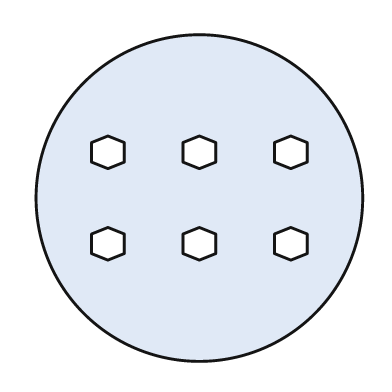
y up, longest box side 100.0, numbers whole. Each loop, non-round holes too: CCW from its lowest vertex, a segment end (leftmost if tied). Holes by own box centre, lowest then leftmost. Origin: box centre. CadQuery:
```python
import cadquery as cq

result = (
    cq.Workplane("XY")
    .moveTo(0.0, 0.0)
    .circle(50.0)
    .moveTo(-28.0, -19.0)
    .lineTo(-23.0, -17.0)
    .lineTo(-23.0, -11.0)
    .lineTo(-28.0, -9.0)
    .lineTo(-33.0, -11.0)
    .lineTo(-33.0, -17.0)
    .close()
    .moveTo(0.0, -19.0)
    .lineTo(5.0, -17.0)
    .lineTo(5.0, -11.0)
    .lineTo(0.0, -9.0)
    .lineTo(-5.0, -11.0)
    .lineTo(-5.0, -17.0)
    .close()
    .moveTo(28.0, -19.0)
    .lineTo(33.0, -17.0)
    .lineTo(33.0, -11.0)
    .lineTo(28.0, -9.0)
    .lineTo(23.0, -11.0)
    .lineTo(23.0, -17.0)
    .close()
    .moveTo(-28.0, 9.0)
    .lineTo(-23.0, 11.0)
    .lineTo(-23.0, 17.0)
    .lineTo(-28.0, 19.0)
    .lineTo(-33.0, 17.0)
    .lineTo(-33.0, 11.0)
    .close()
    .moveTo(0.0, 9.0)
    .lineTo(5.0, 11.0)
    .lineTo(5.0, 17.0)
    .lineTo(0.0, 19.0)
    .lineTo(-5.0, 17.0)
    .lineTo(-5.0, 11.0)
    .close()
    .moveTo(28.0, 9.0)
    .lineTo(33.0, 11.0)
    .lineTo(33.0, 17.0)
    .lineTo(28.0, 19.0)
    .lineTo(23.0, 17.0)
    .lineTo(23.0, 11.0)
    .close()
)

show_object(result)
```